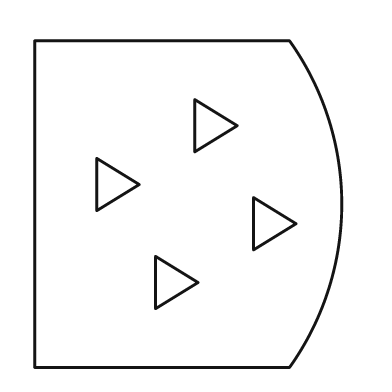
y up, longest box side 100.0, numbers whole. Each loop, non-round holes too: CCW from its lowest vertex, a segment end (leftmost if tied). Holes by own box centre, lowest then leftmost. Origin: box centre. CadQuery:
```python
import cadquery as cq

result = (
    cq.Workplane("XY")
    .moveTo(-47.0, -50.0)
    .lineTo(31.0, -50.0)
    .threePointArc((47.0, 0.0), (31.0, 50.0))
    .lineTo(-47.0, 50.0)
    .close()
    .moveTo(-10.0, -32.0)
    .lineTo(3.0, -24.0)
    .lineTo(-10.0, -16.0)
    .close()
    .moveTo(20.0, -14.0)
    .lineTo(33.0, -6.0)
    .lineTo(20.0, 2.0)
    .close()
    .moveTo(-28.0, -2.0)
    .lineTo(-15.0, 6.0)
    .lineTo(-28.0, 14.0)
    .close()
    .moveTo(2.0, 16.0)
    .lineTo(15.0, 24.0)
    .lineTo(2.0, 32.0)
    .close()
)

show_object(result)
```